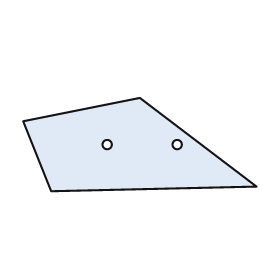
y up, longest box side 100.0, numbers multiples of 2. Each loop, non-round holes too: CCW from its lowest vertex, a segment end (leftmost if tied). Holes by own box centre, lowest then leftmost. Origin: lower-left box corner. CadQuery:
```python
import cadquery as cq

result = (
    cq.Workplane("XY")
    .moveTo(12.0, 0.0)
    .lineTo(100.0, 2.0)
    .lineTo(50.0, 40.0)
    .lineTo(0.0, 30.0)
    .close()
    .moveTo(36.0, 20.0)
    .circle(2.0)
    .moveTo(66.0, 20.0)
    .circle(2.0)
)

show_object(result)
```